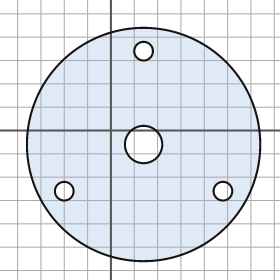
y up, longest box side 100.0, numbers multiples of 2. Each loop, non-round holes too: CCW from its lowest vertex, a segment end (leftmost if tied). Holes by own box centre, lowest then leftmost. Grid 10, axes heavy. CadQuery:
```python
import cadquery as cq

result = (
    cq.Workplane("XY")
    .moveTo(14.0, -6.0)
    .circle(50.0)
    .moveTo(-20.0, -26.0)
    .circle(4.0)
    .moveTo(48.0, -26.0)
    .circle(4.0)
    .moveTo(14.0, -6.0)
    .circle(8.0)
    .moveTo(14.0, 34.0)
    .circle(4.0)
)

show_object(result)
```